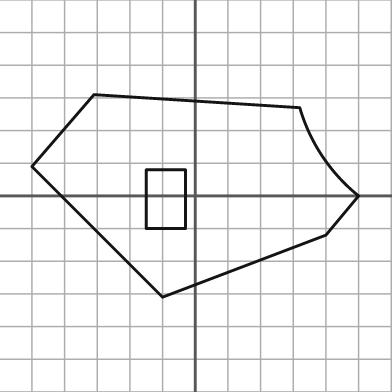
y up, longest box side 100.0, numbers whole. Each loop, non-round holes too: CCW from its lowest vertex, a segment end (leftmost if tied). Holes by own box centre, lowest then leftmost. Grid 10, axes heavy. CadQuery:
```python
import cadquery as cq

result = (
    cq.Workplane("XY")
    .moveTo(-10.0, -31.0)
    .lineTo(40.0, -12.0)
    .lineTo(50.0, 0.0)
    .threePointArc((39.0, 12.0), (32.0, 27.0))
    .lineTo(-31.0, 31.0)
    .lineTo(-50.0, 9.0)
    .close()
    .moveTo(-15.0, -10.0)
    .lineTo(-3.0, -10.0)
    .lineTo(-3.0, 8.0)
    .lineTo(-15.0, 8.0)
    .close()
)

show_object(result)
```